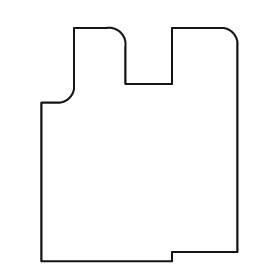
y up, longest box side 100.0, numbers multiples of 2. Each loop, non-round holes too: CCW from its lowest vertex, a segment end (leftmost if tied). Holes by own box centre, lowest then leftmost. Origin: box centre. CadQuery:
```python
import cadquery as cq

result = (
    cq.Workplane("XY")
    .moveTo(-42.0, -50.0)
    .lineTo(14.0, -50.0)
    .lineTo(14.0, -46.0)
    .lineTo(42.0, -46.0)
    .lineTo(42.0, 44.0)
    .threePointArc((40.0, 48.0), (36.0, 50.0))
    .lineTo(14.0, 50.0)
    .lineTo(14.0, 26.0)
    .lineTo(-6.0, 26.0)
    .lineTo(-6.0, 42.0)
    .threePointArc((-8.0, 48.0), (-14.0, 50.0))
    .lineTo(-28.0, 50.0)
    .lineTo(-28.0, 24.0)
    .threePointArc((-30.0, 20.0), (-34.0, 18.0))
    .lineTo(-42.0, 18.0)
    .close()
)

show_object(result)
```